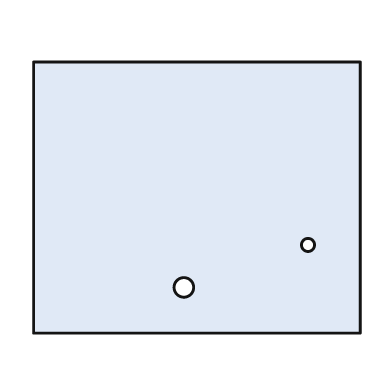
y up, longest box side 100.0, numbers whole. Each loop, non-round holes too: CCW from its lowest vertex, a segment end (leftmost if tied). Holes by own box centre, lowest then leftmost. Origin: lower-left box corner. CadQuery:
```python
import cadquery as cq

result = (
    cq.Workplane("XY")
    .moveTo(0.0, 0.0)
    .lineTo(100.0, 0.0)
    .lineTo(100.0, 83.0)
    .lineTo(0.0, 83.0)
    .close()
    .moveTo(46.0, 14.0)
    .circle(3.0)
    .moveTo(84.0, 27.0)
    .circle(2.0)
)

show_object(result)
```